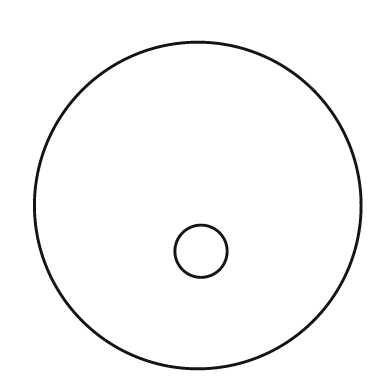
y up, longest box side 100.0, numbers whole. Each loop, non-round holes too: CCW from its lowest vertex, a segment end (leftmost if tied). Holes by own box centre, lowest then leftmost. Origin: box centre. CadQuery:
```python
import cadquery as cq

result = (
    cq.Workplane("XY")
    .moveTo(0.0, 0.0)
    .circle(50.0)
    .moveTo(1.0, -14.0)
    .circle(8.0)
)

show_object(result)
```